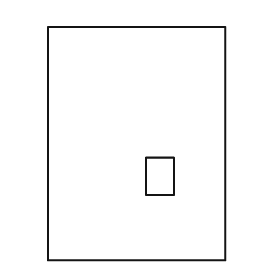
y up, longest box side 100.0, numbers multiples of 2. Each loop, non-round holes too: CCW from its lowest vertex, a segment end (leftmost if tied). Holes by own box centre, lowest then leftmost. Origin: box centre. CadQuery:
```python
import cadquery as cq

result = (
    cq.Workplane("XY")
    .moveTo(-38.0, -50.0)
    .lineTo(38.0, -50.0)
    .lineTo(38.0, 50.0)
    .lineTo(-38.0, 50.0)
    .close()
    .moveTo(4.0, -22.0)
    .lineTo(16.0, -22.0)
    .lineTo(16.0, -6.0)
    .lineTo(4.0, -6.0)
    .close()
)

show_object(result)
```